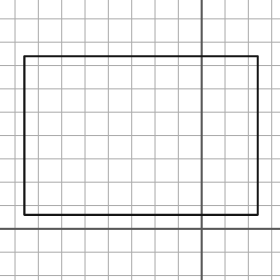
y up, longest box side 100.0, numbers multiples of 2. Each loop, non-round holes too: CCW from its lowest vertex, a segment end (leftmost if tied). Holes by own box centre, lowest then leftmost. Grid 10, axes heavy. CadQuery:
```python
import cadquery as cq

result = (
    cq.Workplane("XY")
    .moveTo(-76.0, 6.0)
    .lineTo(24.0, 6.0)
    .lineTo(24.0, 74.0)
    .lineTo(-76.0, 74.0)
    .close()
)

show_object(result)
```